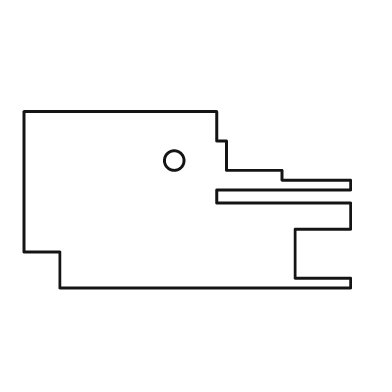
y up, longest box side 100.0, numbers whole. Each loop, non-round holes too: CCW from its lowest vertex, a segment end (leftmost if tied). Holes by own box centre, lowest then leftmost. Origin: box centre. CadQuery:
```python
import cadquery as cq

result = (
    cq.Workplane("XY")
    .moveTo(-39.0, -27.0)
    .lineTo(50.0, -27.0)
    .lineTo(50.0, -24.0)
    .lineTo(33.0, -24.0)
    .lineTo(33.0, -9.0)
    .lineTo(50.0, -9.0)
    .lineTo(50.0, -1.0)
    .lineTo(9.0, -1.0)
    .lineTo(9.0, 3.0)
    .lineTo(50.0, 3.0)
    .lineTo(50.0, 6.0)
    .lineTo(29.0, 6.0)
    .lineTo(29.0, 9.0)
    .lineTo(12.0, 9.0)
    .lineTo(12.0, 18.0)
    .lineTo(9.0, 18.0)
    .lineTo(9.0, 27.0)
    .lineTo(-50.0, 27.0)
    .lineTo(-50.0, -16.0)
    .lineTo(-39.0, -16.0)
    .close()
    .moveTo(-4.0, 12.0)
    .circle(3.0)
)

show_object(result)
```